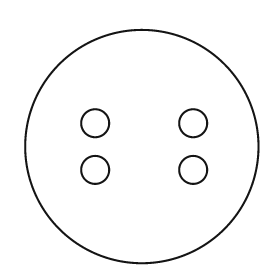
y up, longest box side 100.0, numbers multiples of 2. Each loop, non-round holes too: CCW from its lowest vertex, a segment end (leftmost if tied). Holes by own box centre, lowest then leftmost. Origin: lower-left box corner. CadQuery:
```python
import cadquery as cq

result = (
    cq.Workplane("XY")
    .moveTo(50.0, 50.0)
    .circle(50.0)
    .moveTo(30.0, 40.0)
    .circle(6.0)
    .moveTo(72.0, 40.0)
    .circle(6.0)
    .moveTo(30.0, 60.0)
    .circle(6.0)
    .moveTo(72.0, 60.0)
    .circle(6.0)
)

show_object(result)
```